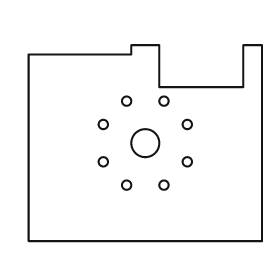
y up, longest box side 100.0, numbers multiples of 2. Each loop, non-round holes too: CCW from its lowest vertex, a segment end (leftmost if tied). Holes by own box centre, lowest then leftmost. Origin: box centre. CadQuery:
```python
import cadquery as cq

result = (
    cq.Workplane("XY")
    .moveTo(-50.0, -42.0)
    .lineTo(50.0, -42.0)
    .lineTo(50.0, 42.0)
    .lineTo(42.0, 42.0)
    .lineTo(42.0, 24.0)
    .lineTo(6.0, 24.0)
    .lineTo(6.0, 42.0)
    .lineTo(-6.0, 42.0)
    .lineTo(-6.0, 38.0)
    .lineTo(-50.0, 38.0)
    .close()
    .moveTo(-8.0, -18.0)
    .circle(2.0)
    .moveTo(8.0, -18.0)
    .circle(2.0)
    .moveTo(-18.0, -8.0)
    .circle(2.0)
    .moveTo(18.0, -8.0)
    .circle(2.0)
    .moveTo(0.0, 0.0)
    .circle(6.0)
    .moveTo(-18.0, 8.0)
    .circle(2.0)
    .moveTo(18.0, 8.0)
    .circle(2.0)
    .moveTo(-8.0, 18.0)
    .circle(2.0)
    .moveTo(8.0, 18.0)
    .circle(2.0)
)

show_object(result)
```